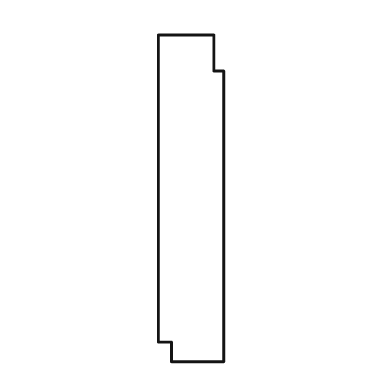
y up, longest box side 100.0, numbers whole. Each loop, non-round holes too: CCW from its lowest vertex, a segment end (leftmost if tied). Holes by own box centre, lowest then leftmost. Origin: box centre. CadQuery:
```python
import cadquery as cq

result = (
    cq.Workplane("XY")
    .moveTo(-6.0, -50.0)
    .lineTo(10.0, -50.0)
    .lineTo(10.0, 39.0)
    .lineTo(7.0, 39.0)
    .lineTo(7.0, 50.0)
    .lineTo(-10.0, 50.0)
    .lineTo(-10.0, -44.0)
    .lineTo(-6.0, -44.0)
    .close()
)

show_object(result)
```